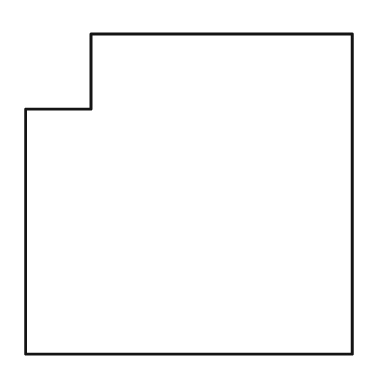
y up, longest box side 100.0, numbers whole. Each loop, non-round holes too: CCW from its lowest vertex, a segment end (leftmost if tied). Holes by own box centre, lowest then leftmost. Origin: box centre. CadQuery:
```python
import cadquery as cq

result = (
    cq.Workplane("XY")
    .moveTo(-50.0, -49.0)
    .lineTo(50.0, -49.0)
    .lineTo(50.0, 49.0)
    .lineTo(-30.0, 49.0)
    .lineTo(-30.0, 26.0)
    .lineTo(-50.0, 26.0)
    .close()
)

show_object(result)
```